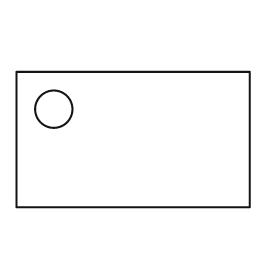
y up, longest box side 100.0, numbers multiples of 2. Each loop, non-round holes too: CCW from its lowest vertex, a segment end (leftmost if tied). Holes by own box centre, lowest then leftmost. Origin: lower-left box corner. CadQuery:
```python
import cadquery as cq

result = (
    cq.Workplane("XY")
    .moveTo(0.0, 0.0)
    .lineTo(100.0, 0.0)
    .lineTo(100.0, 58.0)
    .lineTo(0.0, 58.0)
    .close()
    .moveTo(16.0, 42.0)
    .circle(8.0)
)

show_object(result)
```